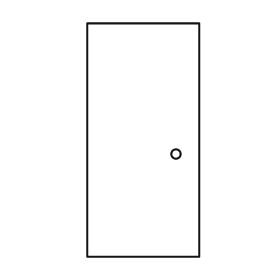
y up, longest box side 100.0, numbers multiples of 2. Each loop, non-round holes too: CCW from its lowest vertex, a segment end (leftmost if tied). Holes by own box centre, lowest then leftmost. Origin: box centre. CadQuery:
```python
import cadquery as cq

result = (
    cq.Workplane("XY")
    .moveTo(-24.0, -50.0)
    .lineTo(24.0, -50.0)
    .lineTo(24.0, 50.0)
    .lineTo(-24.0, 50.0)
    .close()
    .moveTo(14.0, -6.0)
    .circle(2.0)
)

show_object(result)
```